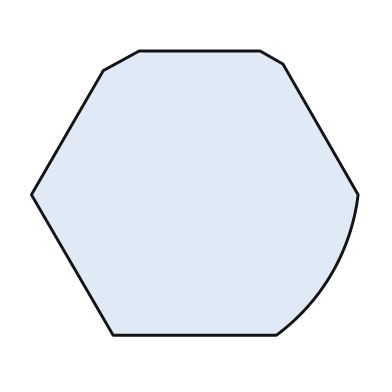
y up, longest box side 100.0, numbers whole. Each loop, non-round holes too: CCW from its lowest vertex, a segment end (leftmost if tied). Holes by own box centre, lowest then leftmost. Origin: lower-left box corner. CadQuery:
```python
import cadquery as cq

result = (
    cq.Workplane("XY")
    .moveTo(25.0, 0.0)
    .lineTo(75.0, 0.0)
    .threePointArc((92.0, 19.0), (100.0, 43.0))
    .lineTo(77.0, 83.0)
    .lineTo(70.0, 87.0)
    .lineTo(33.0, 87.0)
    .lineTo(22.0, 81.0)
    .lineTo(0.0, 43.0)
    .close()
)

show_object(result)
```